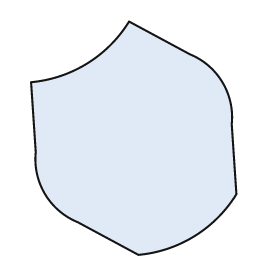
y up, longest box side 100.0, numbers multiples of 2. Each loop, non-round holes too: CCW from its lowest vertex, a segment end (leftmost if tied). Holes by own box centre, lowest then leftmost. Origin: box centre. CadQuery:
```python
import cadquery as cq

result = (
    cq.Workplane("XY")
    .moveTo(2.0, -50.0)
    .threePointArc((26.0, -42.0), (44.0, -24.0))
    .lineTo(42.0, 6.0)
    .threePointArc((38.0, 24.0), (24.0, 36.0))
    .lineTo(-2.0, 50.0)
    .threePointArc((-20.0, 32.0), (-44.0, 24.0))
    .lineTo(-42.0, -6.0)
    .threePointArc((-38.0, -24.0), (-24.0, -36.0))
    .close()
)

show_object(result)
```